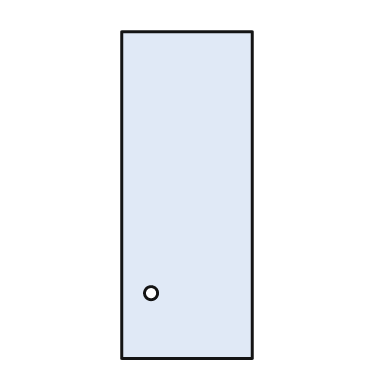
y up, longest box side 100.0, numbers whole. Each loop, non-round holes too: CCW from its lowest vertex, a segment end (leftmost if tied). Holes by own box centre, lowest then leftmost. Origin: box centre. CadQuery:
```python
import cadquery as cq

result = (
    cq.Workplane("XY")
    .moveTo(-20.0, -50.0)
    .lineTo(20.0, -50.0)
    .lineTo(20.0, 50.0)
    .lineTo(-20.0, 50.0)
    .close()
    .moveTo(-11.0, -30.0)
    .circle(2.0)
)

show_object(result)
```